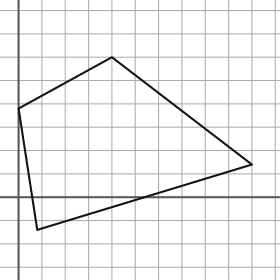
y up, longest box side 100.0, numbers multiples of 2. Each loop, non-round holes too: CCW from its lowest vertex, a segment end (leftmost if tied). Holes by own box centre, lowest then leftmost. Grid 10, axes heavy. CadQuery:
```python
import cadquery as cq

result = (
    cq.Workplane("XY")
    .moveTo(8.0, -14.0)
    .lineTo(100.0, 14.0)
    .lineTo(40.0, 60.0)
    .lineTo(0.0, 38.0)
    .close()
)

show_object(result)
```